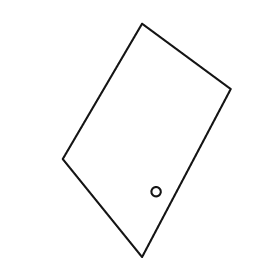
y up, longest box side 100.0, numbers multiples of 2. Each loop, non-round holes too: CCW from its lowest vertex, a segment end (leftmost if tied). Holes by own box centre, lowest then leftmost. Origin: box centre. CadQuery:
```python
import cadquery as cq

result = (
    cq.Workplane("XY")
    .moveTo(-2.0, -50.0)
    .lineTo(36.0, 22.0)
    .lineTo(-2.0, 50.0)
    .lineTo(-36.0, -8.0)
    .close()
    .moveTo(4.0, -22.0)
    .circle(2.0)
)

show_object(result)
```